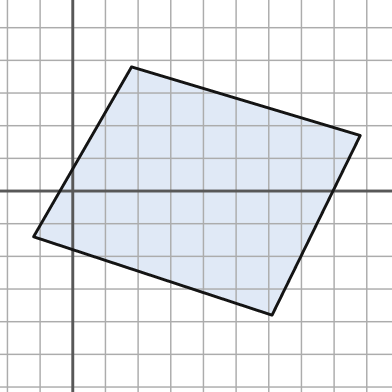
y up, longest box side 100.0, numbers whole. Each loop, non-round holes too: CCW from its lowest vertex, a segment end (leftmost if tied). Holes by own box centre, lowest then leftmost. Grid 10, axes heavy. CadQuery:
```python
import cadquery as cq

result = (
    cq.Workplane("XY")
    .moveTo(61.0, -38.0)
    .lineTo(88.0, 17.0)
    .lineTo(18.0, 38.0)
    .lineTo(-12.0, -14.0)
    .close()
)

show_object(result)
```